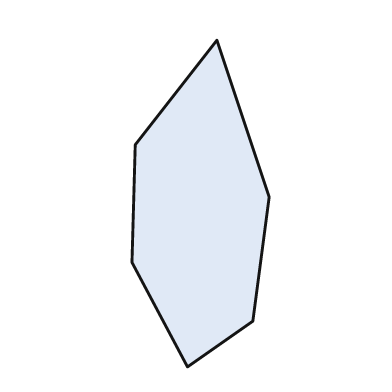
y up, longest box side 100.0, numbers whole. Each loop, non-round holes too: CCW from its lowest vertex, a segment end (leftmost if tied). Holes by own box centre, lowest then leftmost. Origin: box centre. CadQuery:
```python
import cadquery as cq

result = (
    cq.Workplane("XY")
    .moveTo(-4.0, -50.0)
    .lineTo(16.0, -36.0)
    .lineTo(21.0, 2.0)
    .lineTo(5.0, 50.0)
    .lineTo(-20.0, 18.0)
    .lineTo(-21.0, -18.0)
    .close()
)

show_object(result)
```